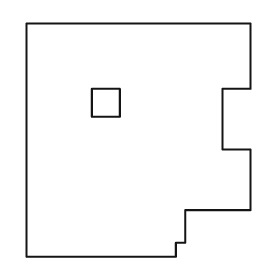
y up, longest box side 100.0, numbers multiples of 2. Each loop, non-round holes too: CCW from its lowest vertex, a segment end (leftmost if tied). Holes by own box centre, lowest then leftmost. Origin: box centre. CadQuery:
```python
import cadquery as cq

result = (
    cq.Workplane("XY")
    .moveTo(-48.0, -50.0)
    .lineTo(16.0, -50.0)
    .lineTo(16.0, -44.0)
    .lineTo(20.0, -44.0)
    .lineTo(20.0, -30.0)
    .lineTo(48.0, -30.0)
    .lineTo(48.0, -4.0)
    .lineTo(36.0, -4.0)
    .lineTo(36.0, 22.0)
    .lineTo(48.0, 22.0)
    .lineTo(48.0, 50.0)
    .lineTo(-48.0, 50.0)
    .close()
    .moveTo(-20.0, 10.0)
    .lineTo(-8.0, 10.0)
    .lineTo(-8.0, 22.0)
    .lineTo(-20.0, 22.0)
    .close()
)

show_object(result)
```